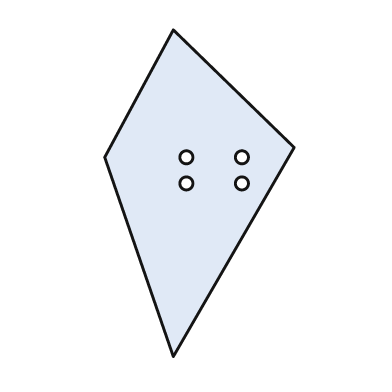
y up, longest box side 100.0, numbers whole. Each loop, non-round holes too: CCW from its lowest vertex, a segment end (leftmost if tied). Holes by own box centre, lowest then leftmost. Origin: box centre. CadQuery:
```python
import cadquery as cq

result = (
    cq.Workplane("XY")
    .moveTo(-8.0, -50.0)
    .lineTo(29.0, 14.0)
    .lineTo(-8.0, 50.0)
    .lineTo(-29.0, 11.0)
    .close()
    .moveTo(-4.0, 3.0)
    .circle(2.0)
    .moveTo(13.0, 3.0)
    .circle(2.0)
    .moveTo(-4.0, 11.0)
    .circle(2.0)
    .moveTo(13.0, 11.0)
    .circle(2.0)
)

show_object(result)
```